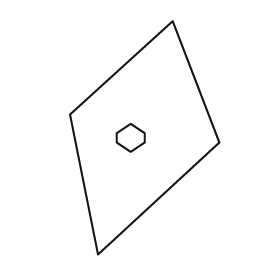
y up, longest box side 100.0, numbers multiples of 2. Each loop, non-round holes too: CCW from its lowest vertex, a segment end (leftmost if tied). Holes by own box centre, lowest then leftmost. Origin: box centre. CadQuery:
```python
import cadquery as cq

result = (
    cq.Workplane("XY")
    .moveTo(-20.0, -50.0)
    .lineTo(32.0, -2.0)
    .lineTo(12.0, 50.0)
    .lineTo(-32.0, 10.0)
    .close()
    .moveTo(-6.0, -6.0)
    .lineTo(0.0, -2.0)
    .lineTo(0.0, 2.0)
    .lineTo(-6.0, 6.0)
    .lineTo(-12.0, 2.0)
    .lineTo(-12.0, -2.0)
    .close()
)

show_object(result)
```